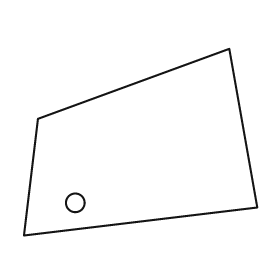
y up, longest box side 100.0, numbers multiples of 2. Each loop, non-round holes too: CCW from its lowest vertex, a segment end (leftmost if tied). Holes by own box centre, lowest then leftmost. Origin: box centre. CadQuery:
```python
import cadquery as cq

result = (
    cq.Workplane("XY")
    .moveTo(-50.0, -40.0)
    .lineTo(50.0, -28.0)
    .lineTo(38.0, 40.0)
    .lineTo(-44.0, 10.0)
    .close()
    .moveTo(-28.0, -26.0)
    .circle(4.0)
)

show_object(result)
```